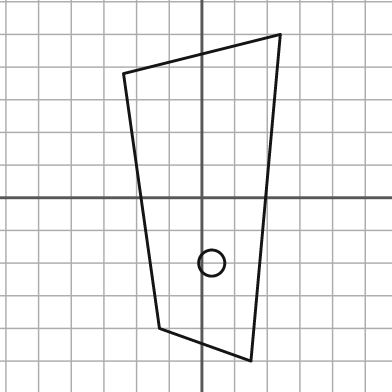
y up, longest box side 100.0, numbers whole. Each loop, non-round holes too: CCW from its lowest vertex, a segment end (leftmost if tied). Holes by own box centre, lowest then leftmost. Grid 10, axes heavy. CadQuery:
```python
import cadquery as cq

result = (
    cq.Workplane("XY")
    .moveTo(15.0, -50.0)
    .lineTo(24.0, 50.0)
    .lineTo(-24.0, 38.0)
    .lineTo(-13.0, -40.0)
    .close()
    .moveTo(3.0, -20.0)
    .circle(4.0)
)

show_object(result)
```